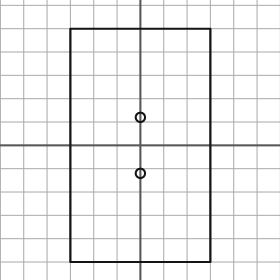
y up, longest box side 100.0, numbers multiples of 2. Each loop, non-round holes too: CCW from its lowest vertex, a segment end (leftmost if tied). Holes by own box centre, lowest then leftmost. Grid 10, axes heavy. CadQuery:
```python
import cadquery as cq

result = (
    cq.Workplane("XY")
    .moveTo(-30.0, -50.0)
    .lineTo(30.0, -50.0)
    .lineTo(30.0, 50.0)
    .lineTo(-30.0, 50.0)
    .close()
    .moveTo(0.0, -12.0)
    .circle(2.0)
    .moveTo(0.0, 12.0)
    .circle(2.0)
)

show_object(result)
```